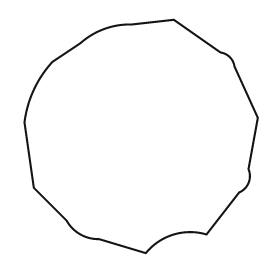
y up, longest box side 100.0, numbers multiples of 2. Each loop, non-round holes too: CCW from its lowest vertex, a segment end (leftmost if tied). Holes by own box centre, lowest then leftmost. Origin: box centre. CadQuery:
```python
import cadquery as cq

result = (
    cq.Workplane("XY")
    .moveTo(2.0, -50.0)
    .threePointArc((14.0, -42.0), (28.0, -42.0))
    .lineTo(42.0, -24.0)
    .threePointArc((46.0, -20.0), (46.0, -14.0))
    .lineTo(50.0, 8.0)
    .lineTo(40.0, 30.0)
    .threePointArc((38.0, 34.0), (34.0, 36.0))
    .lineTo(14.0, 50.0)
    .lineTo(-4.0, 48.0)
    .threePointArc((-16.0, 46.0), (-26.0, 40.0))
    .lineTo(-38.0, 32.0)
    .threePointArc((-46.0, 20.0), (-50.0, 6.0))
    .lineTo(-46.0, -22.0)
    .lineTo(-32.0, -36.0)
    .threePointArc((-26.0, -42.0), (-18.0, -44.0))
    .close()
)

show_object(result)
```